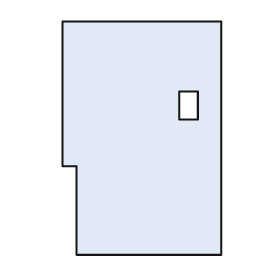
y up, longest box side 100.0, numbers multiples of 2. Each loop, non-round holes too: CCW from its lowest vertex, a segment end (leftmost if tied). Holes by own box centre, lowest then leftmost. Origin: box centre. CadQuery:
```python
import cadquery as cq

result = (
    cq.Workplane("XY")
    .moveTo(-28.0, -50.0)
    .lineTo(34.0, -50.0)
    .lineTo(34.0, 50.0)
    .lineTo(-34.0, 50.0)
    .lineTo(-34.0, -12.0)
    .lineTo(-28.0, -12.0)
    .close()
    .moveTo(16.0, 8.0)
    .lineTo(24.0, 8.0)
    .lineTo(24.0, 20.0)
    .lineTo(16.0, 20.0)
    .close()
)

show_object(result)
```